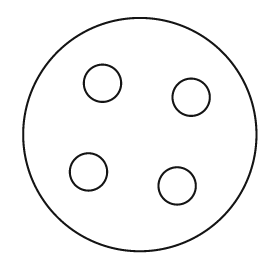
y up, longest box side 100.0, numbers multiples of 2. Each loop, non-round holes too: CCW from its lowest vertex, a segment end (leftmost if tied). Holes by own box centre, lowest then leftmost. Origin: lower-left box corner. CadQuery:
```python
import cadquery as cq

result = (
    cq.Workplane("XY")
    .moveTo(50.0, 50.0)
    .circle(50.0)
    .moveTo(66.0, 28.0)
    .circle(8.0)
    .moveTo(28.0, 34.0)
    .circle(8.0)
    .moveTo(72.0, 66.0)
    .circle(8.0)
    .moveTo(34.0, 72.0)
    .circle(8.0)
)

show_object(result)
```